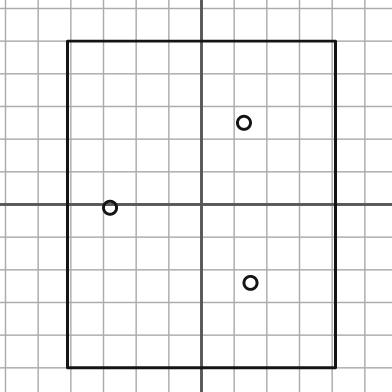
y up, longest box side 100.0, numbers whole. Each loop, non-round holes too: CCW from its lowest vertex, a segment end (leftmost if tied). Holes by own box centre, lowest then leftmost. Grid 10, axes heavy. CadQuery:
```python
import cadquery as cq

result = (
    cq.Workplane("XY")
    .moveTo(-41.0, -50.0)
    .lineTo(41.0, -50.0)
    .lineTo(41.0, 50.0)
    .lineTo(-41.0, 50.0)
    .close()
    .moveTo(15.0, -24.0)
    .circle(2.0)
    .moveTo(-28.0, -1.0)
    .circle(2.0)
    .moveTo(13.0, 25.0)
    .circle(2.0)
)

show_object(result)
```